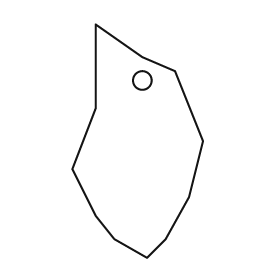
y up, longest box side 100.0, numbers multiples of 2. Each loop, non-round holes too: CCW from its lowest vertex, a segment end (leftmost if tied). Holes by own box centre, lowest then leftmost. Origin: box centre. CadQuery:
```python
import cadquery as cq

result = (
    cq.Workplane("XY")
    .moveTo(4.0, -50.0)
    .lineTo(12.0, -42.0)
    .lineTo(22.0, -24.0)
    .lineTo(28.0, 0.0)
    .lineTo(16.0, 30.0)
    .lineTo(2.0, 36.0)
    .lineTo(-18.0, 50.0)
    .lineTo(-18.0, 14.0)
    .lineTo(-28.0, -12.0)
    .lineTo(-18.0, -32.0)
    .lineTo(-10.0, -42.0)
    .close()
    .moveTo(2.0, 26.0)
    .circle(4.0)
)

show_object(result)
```